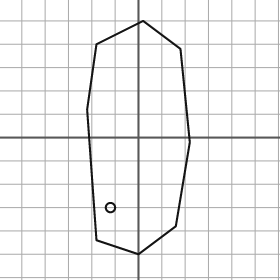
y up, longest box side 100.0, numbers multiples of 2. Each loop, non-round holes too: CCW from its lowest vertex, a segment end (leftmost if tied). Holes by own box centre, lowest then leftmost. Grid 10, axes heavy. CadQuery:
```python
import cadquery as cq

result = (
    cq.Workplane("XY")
    .moveTo(0.0, -50.0)
    .lineTo(16.0, -38.0)
    .lineTo(22.0, -2.0)
    .lineTo(18.0, 38.0)
    .lineTo(2.0, 50.0)
    .lineTo(-18.0, 40.0)
    .lineTo(-22.0, 12.0)
    .lineTo(-18.0, -44.0)
    .close()
    .moveTo(-12.0, -30.0)
    .circle(2.0)
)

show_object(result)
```